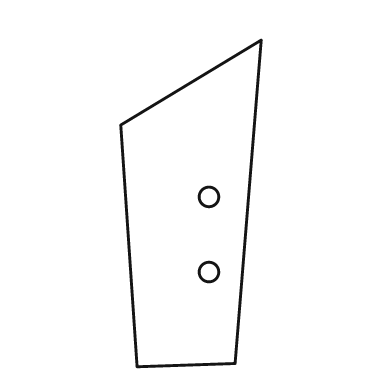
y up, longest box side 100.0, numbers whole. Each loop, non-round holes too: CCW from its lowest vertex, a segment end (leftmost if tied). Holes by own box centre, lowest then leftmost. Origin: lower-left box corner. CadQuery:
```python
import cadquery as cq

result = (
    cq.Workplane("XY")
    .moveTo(5.0, 0.0)
    .lineTo(35.0, 1.0)
    .lineTo(43.0, 100.0)
    .lineTo(0.0, 74.0)
    .close()
    .moveTo(27.0, 29.0)
    .circle(3.0)
    .moveTo(27.0, 52.0)
    .circle(3.0)
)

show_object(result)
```